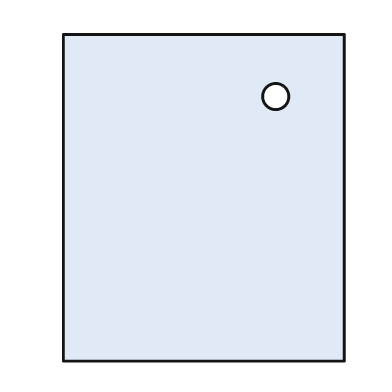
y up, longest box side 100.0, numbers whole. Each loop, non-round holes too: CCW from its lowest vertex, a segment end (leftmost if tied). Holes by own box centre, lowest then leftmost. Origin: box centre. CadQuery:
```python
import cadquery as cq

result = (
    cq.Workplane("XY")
    .moveTo(-43.0, -50.0)
    .lineTo(43.0, -50.0)
    .lineTo(43.0, 50.0)
    .lineTo(-43.0, 50.0)
    .close()
    .moveTo(22.0, 31.0)
    .circle(4.0)
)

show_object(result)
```